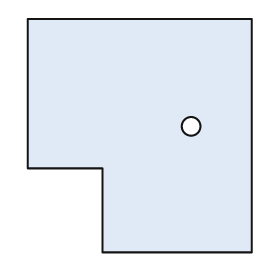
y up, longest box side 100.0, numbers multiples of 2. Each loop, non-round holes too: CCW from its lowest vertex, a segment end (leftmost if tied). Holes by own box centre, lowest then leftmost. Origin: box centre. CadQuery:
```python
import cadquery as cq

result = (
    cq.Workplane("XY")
    .moveTo(-16.0, -50.0)
    .lineTo(48.0, -50.0)
    .lineTo(48.0, 50.0)
    .lineTo(-48.0, 50.0)
    .lineTo(-48.0, -14.0)
    .lineTo(-16.0, -14.0)
    .close()
    .moveTo(22.0, 4.0)
    .circle(4.0)
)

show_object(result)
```